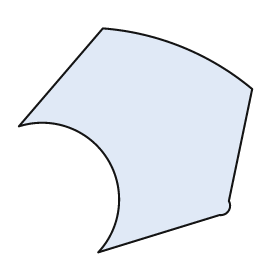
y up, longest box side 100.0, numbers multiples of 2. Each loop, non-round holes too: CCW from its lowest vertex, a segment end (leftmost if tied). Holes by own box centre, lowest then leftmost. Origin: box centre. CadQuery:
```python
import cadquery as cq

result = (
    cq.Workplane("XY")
    .moveTo(-16.0, -48.0)
    .lineTo(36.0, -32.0)
    .threePointArc((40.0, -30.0), (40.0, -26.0))
    .lineTo(50.0, 22.0)
    .threePointArc((20.0, 40.0), (-14.0, 48.0))
    .lineTo(-50.0, 6.0)
    .threePointArc((-12.0, -8.0), (-16.0, -48.0))
    .close()
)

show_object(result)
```